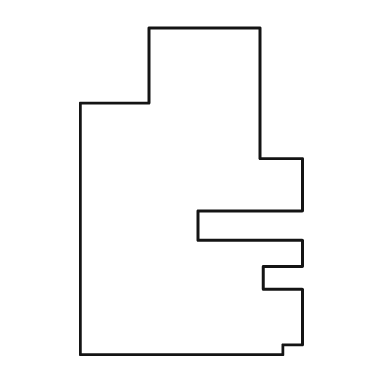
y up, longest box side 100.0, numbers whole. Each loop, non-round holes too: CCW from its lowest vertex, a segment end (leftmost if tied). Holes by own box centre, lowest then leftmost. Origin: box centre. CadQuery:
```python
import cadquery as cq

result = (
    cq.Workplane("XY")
    .moveTo(-34.0, -50.0)
    .lineTo(28.0, -50.0)
    .lineTo(28.0, -47.0)
    .lineTo(34.0, -47.0)
    .lineTo(34.0, -30.0)
    .lineTo(22.0, -30.0)
    .lineTo(22.0, -23.0)
    .lineTo(34.0, -23.0)
    .lineTo(34.0, -15.0)
    .lineTo(2.0, -15.0)
    .lineTo(2.0, -6.0)
    .lineTo(34.0, -6.0)
    .lineTo(34.0, 10.0)
    .lineTo(21.0, 10.0)
    .lineTo(21.0, 50.0)
    .lineTo(-13.0, 50.0)
    .lineTo(-13.0, 27.0)
    .lineTo(-34.0, 27.0)
    .close()
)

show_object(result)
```